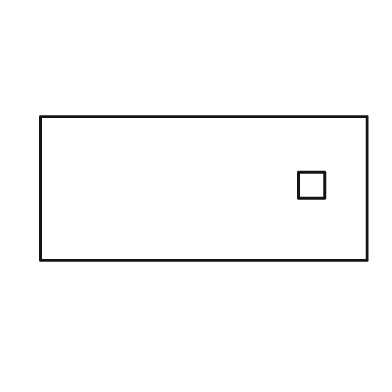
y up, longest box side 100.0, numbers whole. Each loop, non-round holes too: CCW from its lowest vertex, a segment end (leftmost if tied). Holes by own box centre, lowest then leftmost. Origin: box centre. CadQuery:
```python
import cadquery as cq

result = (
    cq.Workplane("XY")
    .moveTo(-50.0, -22.0)
    .lineTo(50.0, -22.0)
    .lineTo(50.0, 22.0)
    .lineTo(-50.0, 22.0)
    .close()
    .moveTo(29.0, -3.0)
    .lineTo(37.0, -3.0)
    .lineTo(37.0, 5.0)
    .lineTo(29.0, 5.0)
    .close()
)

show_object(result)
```